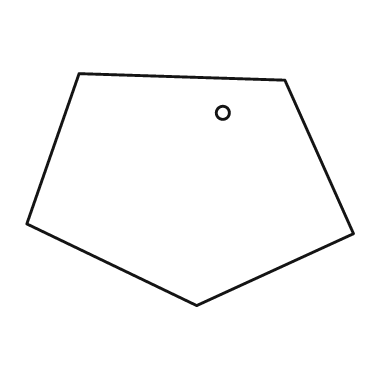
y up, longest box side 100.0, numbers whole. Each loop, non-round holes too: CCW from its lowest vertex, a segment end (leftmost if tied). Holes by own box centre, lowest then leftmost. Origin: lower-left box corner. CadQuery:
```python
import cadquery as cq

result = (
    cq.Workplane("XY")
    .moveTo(52.0, 0.0)
    .lineTo(100.0, 22.0)
    .lineTo(79.0, 69.0)
    .lineTo(16.0, 71.0)
    .lineTo(0.0, 25.0)
    .close()
    .moveTo(60.0, 59.0)
    .circle(2.0)
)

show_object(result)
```